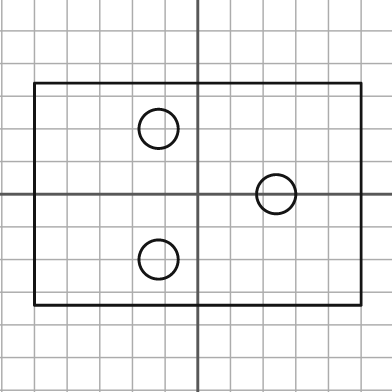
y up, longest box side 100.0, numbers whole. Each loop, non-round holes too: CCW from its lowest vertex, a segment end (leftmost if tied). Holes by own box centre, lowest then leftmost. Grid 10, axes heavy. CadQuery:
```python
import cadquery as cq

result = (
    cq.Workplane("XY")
    .moveTo(-50.0, -34.0)
    .lineTo(50.0, -34.0)
    .lineTo(50.0, 34.0)
    .lineTo(-50.0, 34.0)
    .close()
    .moveTo(-12.0, -20.0)
    .circle(6.0)
    .moveTo(24.0, 0.0)
    .circle(6.0)
    .moveTo(-12.0, 20.0)
    .circle(6.0)
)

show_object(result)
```